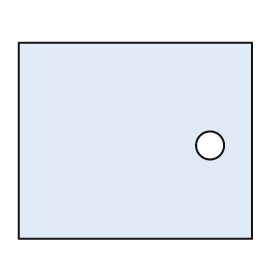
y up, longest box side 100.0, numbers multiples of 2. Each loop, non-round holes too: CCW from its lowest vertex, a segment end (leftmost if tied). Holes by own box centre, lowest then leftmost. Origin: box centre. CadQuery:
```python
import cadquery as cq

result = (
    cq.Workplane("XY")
    .moveTo(-50.0, -42.0)
    .lineTo(50.0, -42.0)
    .lineTo(50.0, 42.0)
    .lineTo(-50.0, 42.0)
    .close()
    .moveTo(32.0, -2.0)
    .circle(6.0)
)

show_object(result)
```